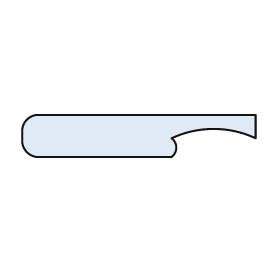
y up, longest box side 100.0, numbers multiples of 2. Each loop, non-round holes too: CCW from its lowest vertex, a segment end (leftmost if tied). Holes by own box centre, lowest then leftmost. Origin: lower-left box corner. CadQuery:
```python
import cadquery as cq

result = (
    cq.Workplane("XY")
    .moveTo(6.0, 0.0)
    .lineTo(64.0, 0.0)
    .threePointArc((66.0, 4.0), (64.0, 8.0))
    .threePointArc((82.0, 12.0), (100.0, 8.0))
    .lineTo(100.0, 18.0)
    .lineTo(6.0, 18.0)
    .threePointArc((2.0, 16.0), (0.0, 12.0))
    .lineTo(0.0, 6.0)
    .threePointArc((2.0, 2.0), (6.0, 0.0))
    .close()
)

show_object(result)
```